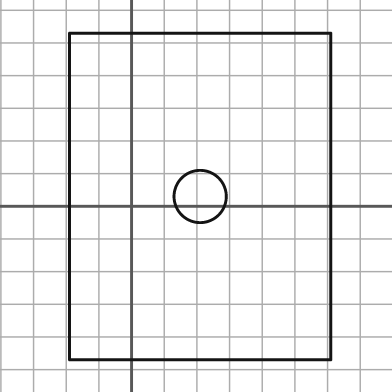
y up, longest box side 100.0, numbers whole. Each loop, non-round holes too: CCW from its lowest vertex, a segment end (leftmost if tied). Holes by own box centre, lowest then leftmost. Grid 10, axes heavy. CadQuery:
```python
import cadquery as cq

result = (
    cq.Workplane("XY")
    .moveTo(-19.0, -47.0)
    .lineTo(61.0, -47.0)
    .lineTo(61.0, 53.0)
    .lineTo(-19.0, 53.0)
    .close()
    .moveTo(21.0, 3.0)
    .circle(8.0)
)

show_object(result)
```